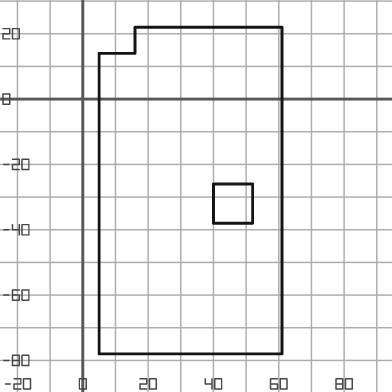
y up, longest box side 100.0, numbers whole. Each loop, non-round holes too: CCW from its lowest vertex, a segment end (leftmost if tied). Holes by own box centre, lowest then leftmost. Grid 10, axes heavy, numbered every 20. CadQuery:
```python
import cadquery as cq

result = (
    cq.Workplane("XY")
    .moveTo(5.0, -78.0)
    .lineTo(61.0, -78.0)
    .lineTo(61.0, 22.0)
    .lineTo(16.0, 22.0)
    .lineTo(16.0, 14.0)
    .lineTo(5.0, 14.0)
    .close()
    .moveTo(40.0, -38.0)
    .lineTo(52.0, -38.0)
    .lineTo(52.0, -26.0)
    .lineTo(40.0, -26.0)
    .close()
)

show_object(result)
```